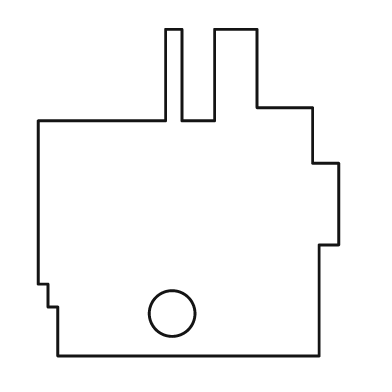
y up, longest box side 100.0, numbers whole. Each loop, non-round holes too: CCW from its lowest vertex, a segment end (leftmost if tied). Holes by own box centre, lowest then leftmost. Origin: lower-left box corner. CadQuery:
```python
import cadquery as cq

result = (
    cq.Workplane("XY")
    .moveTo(6.0, 0.0)
    .lineTo(86.0, 0.0)
    .lineTo(86.0, 34.0)
    .lineTo(92.0, 34.0)
    .lineTo(92.0, 59.0)
    .lineTo(84.0, 59.0)
    .lineTo(84.0, 76.0)
    .lineTo(67.0, 76.0)
    .lineTo(67.0, 100.0)
    .lineTo(54.0, 100.0)
    .lineTo(54.0, 72.0)
    .lineTo(44.0, 72.0)
    .lineTo(44.0, 100.0)
    .lineTo(39.0, 100.0)
    .lineTo(39.0, 72.0)
    .lineTo(0.0, 72.0)
    .lineTo(0.0, 22.0)
    .lineTo(3.0, 22.0)
    .lineTo(3.0, 15.0)
    .lineTo(6.0, 15.0)
    .close()
    .moveTo(41.0, 13.0)
    .circle(7.0)
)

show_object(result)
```